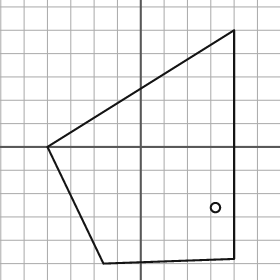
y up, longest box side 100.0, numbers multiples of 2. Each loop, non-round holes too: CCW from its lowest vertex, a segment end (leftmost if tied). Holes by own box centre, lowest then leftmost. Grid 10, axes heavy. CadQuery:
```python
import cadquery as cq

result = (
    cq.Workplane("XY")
    .moveTo(-16.0, -50.0)
    .lineTo(40.0, -48.0)
    .lineTo(40.0, 50.0)
    .lineTo(-40.0, 0.0)
    .close()
    .moveTo(32.0, -26.0)
    .circle(2.0)
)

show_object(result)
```